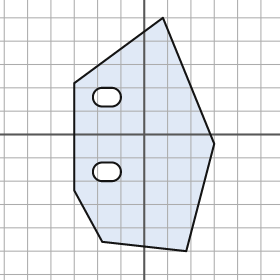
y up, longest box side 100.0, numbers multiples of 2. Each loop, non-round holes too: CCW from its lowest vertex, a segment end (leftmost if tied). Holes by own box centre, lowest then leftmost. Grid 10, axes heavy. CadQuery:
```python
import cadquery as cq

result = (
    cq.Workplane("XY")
    .moveTo(18.0, -50.0)
    .lineTo(30.0, -4.0)
    .lineTo(8.0, 50.0)
    .lineTo(-30.0, 22.0)
    .lineTo(-30.0, -24.0)
    .lineTo(-18.0, -46.0)
    .close()
    .moveTo(-18.0, -20.0)
    .lineTo(-14.0, -20.0)
    .threePointArc((-10.0, -16.0), (-14.0, -12.0))
    .lineTo(-18.0, -12.0)
    .threePointArc((-22.0, -16.0), (-18.0, -20.0))
    .close()
    .moveTo(-18.0, 12.0)
    .lineTo(-14.0, 12.0)
    .threePointArc((-10.0, 16.0), (-14.0, 20.0))
    .lineTo(-18.0, 20.0)
    .threePointArc((-22.0, 16.0), (-18.0, 12.0))
    .close()
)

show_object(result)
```